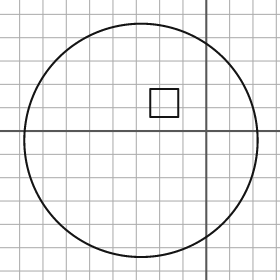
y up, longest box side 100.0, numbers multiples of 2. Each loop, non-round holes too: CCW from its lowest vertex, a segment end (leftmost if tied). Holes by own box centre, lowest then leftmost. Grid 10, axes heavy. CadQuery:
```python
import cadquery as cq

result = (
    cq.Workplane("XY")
    .moveTo(-28.0, -4.0)
    .circle(50.0)
    .moveTo(-24.0, 6.0)
    .lineTo(-12.0, 6.0)
    .lineTo(-12.0, 18.0)
    .lineTo(-24.0, 18.0)
    .close()
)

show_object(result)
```